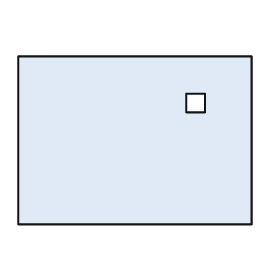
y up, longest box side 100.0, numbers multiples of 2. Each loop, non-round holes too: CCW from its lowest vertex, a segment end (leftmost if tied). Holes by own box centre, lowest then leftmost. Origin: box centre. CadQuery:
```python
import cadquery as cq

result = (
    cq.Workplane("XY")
    .moveTo(-50.0, -36.0)
    .lineTo(50.0, -36.0)
    .lineTo(50.0, 36.0)
    .lineTo(-50.0, 36.0)
    .close()
    .moveTo(22.0, 12.0)
    .lineTo(30.0, 12.0)
    .lineTo(30.0, 20.0)
    .lineTo(22.0, 20.0)
    .close()
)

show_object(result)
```